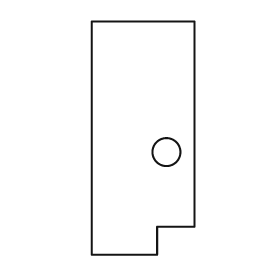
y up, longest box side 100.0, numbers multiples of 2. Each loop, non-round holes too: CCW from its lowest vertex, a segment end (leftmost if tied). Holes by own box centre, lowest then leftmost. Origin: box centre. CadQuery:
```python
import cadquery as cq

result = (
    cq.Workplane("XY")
    .moveTo(-22.0, -50.0)
    .lineTo(6.0, -50.0)
    .lineTo(6.0, -38.0)
    .lineTo(22.0, -38.0)
    .lineTo(22.0, 50.0)
    .lineTo(-22.0, 50.0)
    .close()
    .moveTo(10.0, -6.0)
    .circle(6.0)
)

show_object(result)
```